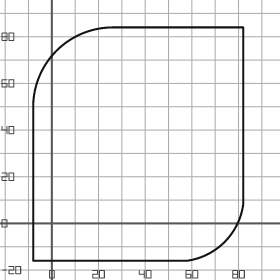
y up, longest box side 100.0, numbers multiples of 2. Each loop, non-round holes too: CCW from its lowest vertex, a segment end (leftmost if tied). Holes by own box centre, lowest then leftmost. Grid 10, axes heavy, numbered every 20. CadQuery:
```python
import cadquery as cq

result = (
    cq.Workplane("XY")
    .moveTo(-8.0, -16.0)
    .lineTo(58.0, -16.0)
    .threePointArc((74.0, -8.0), (82.0, 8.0))
    .lineTo(82.0, 84.0)
    .lineTo(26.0, 84.0)
    .threePointArc((2.0, 74.0), (-8.0, 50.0))
    .close()
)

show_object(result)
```